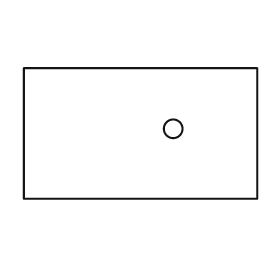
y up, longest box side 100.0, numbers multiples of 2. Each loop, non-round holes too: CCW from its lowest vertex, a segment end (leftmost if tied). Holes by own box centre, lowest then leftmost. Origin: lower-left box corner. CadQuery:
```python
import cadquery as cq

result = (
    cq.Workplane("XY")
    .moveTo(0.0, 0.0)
    .lineTo(100.0, 0.0)
    .lineTo(100.0, 56.0)
    .lineTo(0.0, 56.0)
    .close()
    .moveTo(64.0, 30.0)
    .circle(4.0)
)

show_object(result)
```